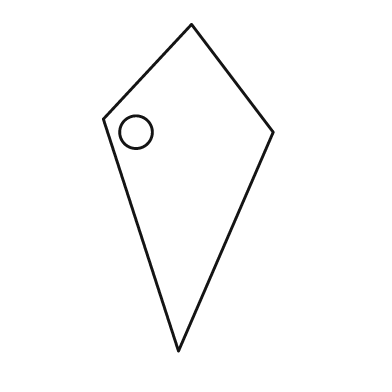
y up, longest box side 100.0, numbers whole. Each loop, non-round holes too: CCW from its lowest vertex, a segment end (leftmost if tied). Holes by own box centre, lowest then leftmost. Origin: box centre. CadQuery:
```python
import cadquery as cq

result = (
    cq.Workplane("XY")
    .moveTo(-3.0, -50.0)
    .lineTo(26.0, 17.0)
    .lineTo(1.0, 50.0)
    .lineTo(-26.0, 21.0)
    .close()
    .moveTo(-16.0, 17.0)
    .circle(5.0)
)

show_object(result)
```